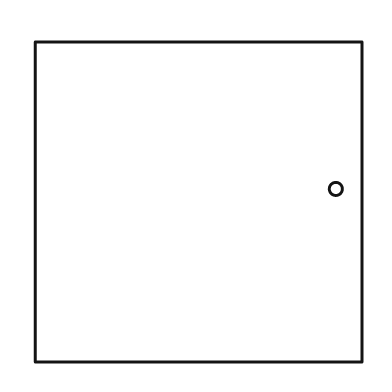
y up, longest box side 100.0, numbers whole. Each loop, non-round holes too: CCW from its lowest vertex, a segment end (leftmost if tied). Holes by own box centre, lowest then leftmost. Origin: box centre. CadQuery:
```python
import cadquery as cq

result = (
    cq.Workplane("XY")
    .moveTo(-50.0, -49.0)
    .lineTo(50.0, -49.0)
    .lineTo(50.0, 49.0)
    .lineTo(-50.0, 49.0)
    .close()
    .moveTo(42.0, 4.0)
    .circle(2.0)
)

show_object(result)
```